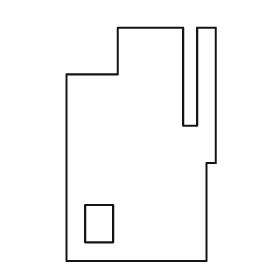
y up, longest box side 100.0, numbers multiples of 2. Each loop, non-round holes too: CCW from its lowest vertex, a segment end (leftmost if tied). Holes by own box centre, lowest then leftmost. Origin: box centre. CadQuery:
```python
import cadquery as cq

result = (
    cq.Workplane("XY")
    .moveTo(-32.0, -50.0)
    .lineTo(28.0, -50.0)
    .lineTo(28.0, -8.0)
    .lineTo(32.0, -8.0)
    .lineTo(32.0, 50.0)
    .lineTo(24.0, 50.0)
    .lineTo(24.0, 8.0)
    .lineTo(18.0, 8.0)
    .lineTo(18.0, 50.0)
    .lineTo(-10.0, 50.0)
    .lineTo(-10.0, 30.0)
    .lineTo(-32.0, 30.0)
    .close()
    .moveTo(-24.0, -42.0)
    .lineTo(-12.0, -42.0)
    .lineTo(-12.0, -26.0)
    .lineTo(-24.0, -26.0)
    .close()
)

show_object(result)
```